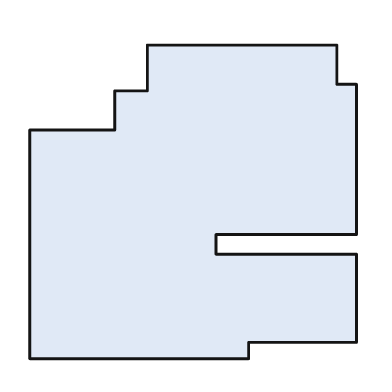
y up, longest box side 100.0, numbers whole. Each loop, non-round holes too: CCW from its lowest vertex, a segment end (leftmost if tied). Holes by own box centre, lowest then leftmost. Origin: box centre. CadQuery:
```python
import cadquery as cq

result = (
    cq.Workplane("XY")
    .moveTo(-50.0, -48.0)
    .lineTo(17.0, -48.0)
    .lineTo(17.0, -43.0)
    .lineTo(50.0, -43.0)
    .lineTo(50.0, -16.0)
    .lineTo(7.0, -16.0)
    .lineTo(7.0, -10.0)
    .lineTo(50.0, -10.0)
    .lineTo(50.0, 36.0)
    .lineTo(44.0, 36.0)
    .lineTo(44.0, 48.0)
    .lineTo(-14.0, 48.0)
    .lineTo(-14.0, 34.0)
    .lineTo(-24.0, 34.0)
    .lineTo(-24.0, 22.0)
    .lineTo(-50.0, 22.0)
    .close()
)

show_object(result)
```